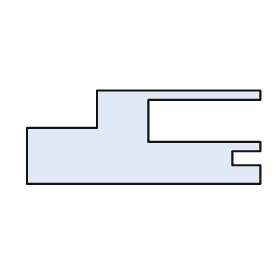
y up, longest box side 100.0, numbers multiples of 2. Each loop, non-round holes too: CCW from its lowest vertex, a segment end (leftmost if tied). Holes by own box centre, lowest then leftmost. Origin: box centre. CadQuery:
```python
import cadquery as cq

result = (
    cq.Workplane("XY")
    .moveTo(-50.0, -20.0)
    .lineTo(50.0, -20.0)
    .lineTo(50.0, -12.0)
    .lineTo(38.0, -12.0)
    .lineTo(38.0, -6.0)
    .lineTo(50.0, -6.0)
    .lineTo(50.0, -2.0)
    .lineTo(2.0, -2.0)
    .lineTo(2.0, 16.0)
    .lineTo(50.0, 16.0)
    .lineTo(50.0, 20.0)
    .lineTo(-20.0, 20.0)
    .lineTo(-20.0, 4.0)
    .lineTo(-50.0, 4.0)
    .close()
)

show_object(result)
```